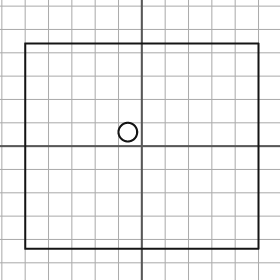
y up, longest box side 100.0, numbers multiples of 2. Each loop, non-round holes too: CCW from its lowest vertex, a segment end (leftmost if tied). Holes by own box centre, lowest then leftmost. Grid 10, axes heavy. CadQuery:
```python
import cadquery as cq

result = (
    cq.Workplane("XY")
    .moveTo(-50.0, -44.0)
    .lineTo(50.0, -44.0)
    .lineTo(50.0, 44.0)
    .lineTo(-50.0, 44.0)
    .close()
    .moveTo(-6.0, 6.0)
    .circle(4.0)
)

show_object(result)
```